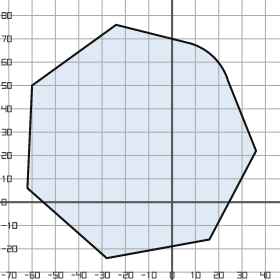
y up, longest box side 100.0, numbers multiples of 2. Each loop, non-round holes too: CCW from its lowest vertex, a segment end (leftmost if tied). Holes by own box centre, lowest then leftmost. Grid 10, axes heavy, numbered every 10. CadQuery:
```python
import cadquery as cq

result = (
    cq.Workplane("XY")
    .moveTo(-28.0, -24.0)
    .lineTo(16.0, -16.0)
    .lineTo(36.0, 22.0)
    .lineTo(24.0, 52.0)
    .threePointArc((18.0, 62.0), (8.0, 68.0))
    .lineTo(-24.0, 76.0)
    .lineTo(-60.0, 50.0)
    .lineTo(-62.0, 6.0)
    .close()
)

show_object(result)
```